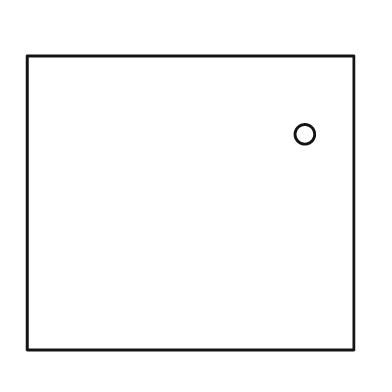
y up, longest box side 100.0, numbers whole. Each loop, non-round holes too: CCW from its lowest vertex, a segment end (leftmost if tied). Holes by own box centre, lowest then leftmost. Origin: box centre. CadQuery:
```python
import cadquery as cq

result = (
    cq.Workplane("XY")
    .moveTo(-50.0, -45.0)
    .lineTo(50.0, -45.0)
    .lineTo(50.0, 45.0)
    .lineTo(-50.0, 45.0)
    .close()
    .moveTo(35.0, 21.0)
    .circle(3.0)
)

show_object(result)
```